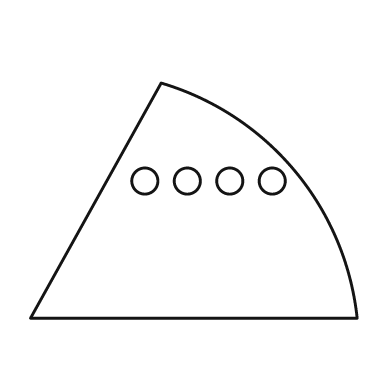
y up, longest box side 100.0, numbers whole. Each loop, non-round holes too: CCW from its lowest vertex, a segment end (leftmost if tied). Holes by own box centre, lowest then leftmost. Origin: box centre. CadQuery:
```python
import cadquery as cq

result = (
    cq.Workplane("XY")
    .moveTo(-50.0, -36.0)
    .lineTo(50.0, -36.0)
    .threePointArc((31.0, 9.0), (-10.0, 36.0))
    .close()
    .moveTo(-15.0, 6.0)
    .circle(4.0)
    .moveTo(-2.0, 6.0)
    .circle(4.0)
    .moveTo(11.0, 6.0)
    .circle(4.0)
    .moveTo(24.0, 6.0)
    .circle(4.0)
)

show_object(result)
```